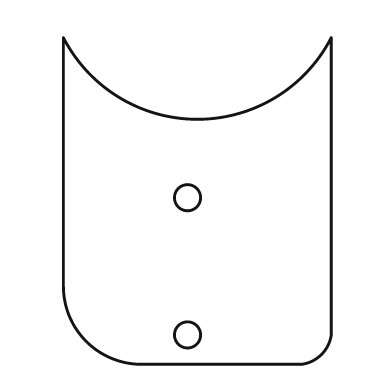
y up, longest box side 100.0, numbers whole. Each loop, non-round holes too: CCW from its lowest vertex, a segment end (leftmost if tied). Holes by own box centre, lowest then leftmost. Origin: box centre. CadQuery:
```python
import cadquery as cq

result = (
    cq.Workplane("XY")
    .moveTo(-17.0, -50.0)
    .lineTo(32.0, -50.0)
    .threePointArc((38.0, -47.0), (41.0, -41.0))
    .lineTo(41.0, 50.0)
    .threePointArc((0.0, 25.0), (-41.0, 50.0))
    .lineTo(-41.0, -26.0)
    .threePointArc((-34.0, -43.0), (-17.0, -50.0))
    .close()
    .moveTo(-3.0, -41.0)
    .circle(4.0)
    .moveTo(-3.0, 1.0)
    .circle(4.0)
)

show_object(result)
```